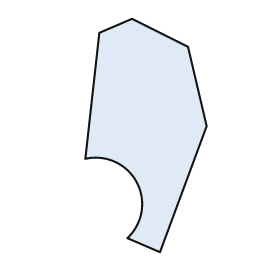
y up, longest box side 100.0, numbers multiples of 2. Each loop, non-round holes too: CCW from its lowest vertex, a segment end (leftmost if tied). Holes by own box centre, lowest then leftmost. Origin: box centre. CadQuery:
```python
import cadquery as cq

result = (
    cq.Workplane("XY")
    .moveTo(6.0, -50.0)
    .lineTo(26.0, 4.0)
    .lineTo(18.0, 38.0)
    .lineTo(-6.0, 50.0)
    .lineTo(-20.0, 44.0)
    .lineTo(-26.0, -10.0)
    .threePointArc((-4.0, -20.0), (-8.0, -44.0))
    .close()
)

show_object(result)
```